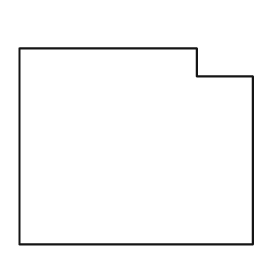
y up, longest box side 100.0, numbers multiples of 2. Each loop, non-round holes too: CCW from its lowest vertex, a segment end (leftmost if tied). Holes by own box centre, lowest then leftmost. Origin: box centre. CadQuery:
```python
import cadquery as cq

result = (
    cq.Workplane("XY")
    .moveTo(-50.0, -42.0)
    .lineTo(50.0, -42.0)
    .lineTo(50.0, 30.0)
    .lineTo(26.0, 30.0)
    .lineTo(26.0, 42.0)
    .lineTo(-50.0, 42.0)
    .close()
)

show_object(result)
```